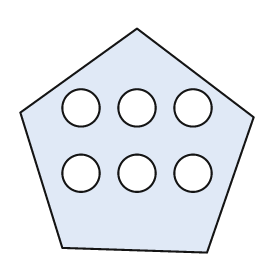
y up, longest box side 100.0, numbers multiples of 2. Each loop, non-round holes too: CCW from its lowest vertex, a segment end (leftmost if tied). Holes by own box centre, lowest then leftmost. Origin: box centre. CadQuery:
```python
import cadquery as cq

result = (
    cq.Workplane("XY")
    .moveTo(30.0, -48.0)
    .lineTo(50.0, 10.0)
    .lineTo(0.0, 48.0)
    .lineTo(-50.0, 12.0)
    .lineTo(-32.0, -46.0)
    .close()
    .moveTo(-24.0, -14.0)
    .circle(8.0)
    .moveTo(0.0, -14.0)
    .circle(8.0)
    .moveTo(24.0, -14.0)
    .circle(8.0)
    .moveTo(-24.0, 14.0)
    .circle(8.0)
    .moveTo(0.0, 14.0)
    .circle(8.0)
    .moveTo(24.0, 14.0)
    .circle(8.0)
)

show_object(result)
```